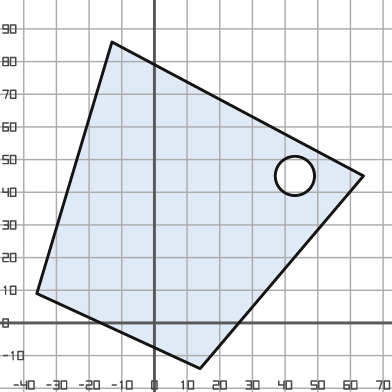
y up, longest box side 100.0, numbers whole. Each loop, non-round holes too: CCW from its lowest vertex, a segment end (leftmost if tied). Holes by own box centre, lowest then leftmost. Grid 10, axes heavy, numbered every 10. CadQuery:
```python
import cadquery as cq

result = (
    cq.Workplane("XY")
    .moveTo(14.0, -14.0)
    .lineTo(64.0, 45.0)
    .lineTo(-13.0, 86.0)
    .lineTo(-36.0, 9.0)
    .close()
    .moveTo(43.0, 45.0)
    .circle(6.0)
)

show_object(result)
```